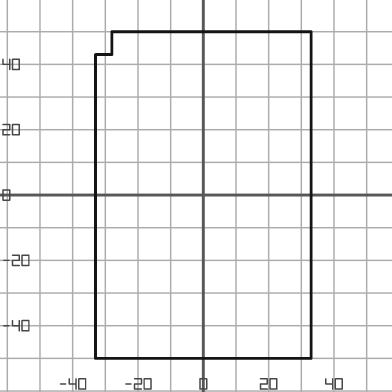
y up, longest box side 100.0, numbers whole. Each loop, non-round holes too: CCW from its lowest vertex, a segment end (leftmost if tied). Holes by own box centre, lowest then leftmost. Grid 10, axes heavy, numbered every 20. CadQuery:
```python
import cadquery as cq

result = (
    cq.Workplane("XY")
    .moveTo(-33.0, -50.0)
    .lineTo(33.0, -50.0)
    .lineTo(33.0, 50.0)
    .lineTo(-28.0, 50.0)
    .lineTo(-28.0, 43.0)
    .lineTo(-33.0, 43.0)
    .close()
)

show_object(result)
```